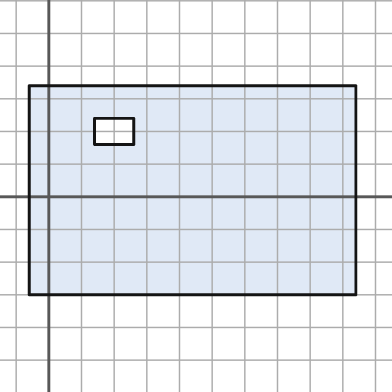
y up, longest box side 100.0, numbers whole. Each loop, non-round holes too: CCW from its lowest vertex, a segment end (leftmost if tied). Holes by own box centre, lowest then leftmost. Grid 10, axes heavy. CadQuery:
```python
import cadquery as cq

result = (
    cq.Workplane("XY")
    .moveTo(-6.0, -30.0)
    .lineTo(94.0, -30.0)
    .lineTo(94.0, 34.0)
    .lineTo(-6.0, 34.0)
    .close()
    .moveTo(14.0, 16.0)
    .lineTo(26.0, 16.0)
    .lineTo(26.0, 24.0)
    .lineTo(14.0, 24.0)
    .close()
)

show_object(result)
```